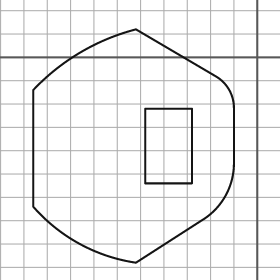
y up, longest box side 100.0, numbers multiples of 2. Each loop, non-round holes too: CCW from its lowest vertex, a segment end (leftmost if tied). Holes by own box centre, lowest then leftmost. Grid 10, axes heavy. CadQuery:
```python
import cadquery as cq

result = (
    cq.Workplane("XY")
    .moveTo(-52.0, -88.0)
    .lineTo(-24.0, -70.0)
    .threePointArc((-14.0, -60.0), (-10.0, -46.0))
    .lineTo(-10.0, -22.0)
    .threePointArc((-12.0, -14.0), (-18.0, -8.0))
    .lineTo(-52.0, 12.0)
    .threePointArc((-76.0, 2.0), (-96.0, -14.0))
    .lineTo(-96.0, -64.0)
    .threePointArc((-76.0, -80.0), (-52.0, -88.0))
    .close()
    .moveTo(-48.0, -54.0)
    .lineTo(-28.0, -54.0)
    .lineTo(-28.0, -22.0)
    .lineTo(-48.0, -22.0)
    .close()
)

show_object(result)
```